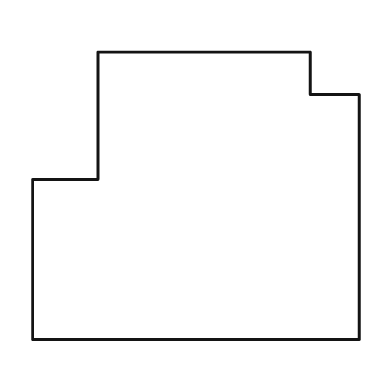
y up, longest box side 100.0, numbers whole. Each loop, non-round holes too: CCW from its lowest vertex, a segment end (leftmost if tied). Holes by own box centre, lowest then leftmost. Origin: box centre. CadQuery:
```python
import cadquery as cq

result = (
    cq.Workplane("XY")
    .moveTo(-50.0, -44.0)
    .lineTo(50.0, -44.0)
    .lineTo(50.0, 31.0)
    .lineTo(35.0, 31.0)
    .lineTo(35.0, 44.0)
    .lineTo(-30.0, 44.0)
    .lineTo(-30.0, 5.0)
    .lineTo(-50.0, 5.0)
    .close()
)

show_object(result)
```